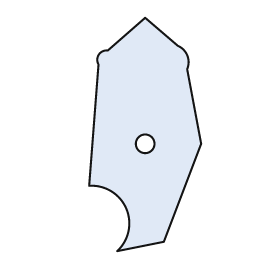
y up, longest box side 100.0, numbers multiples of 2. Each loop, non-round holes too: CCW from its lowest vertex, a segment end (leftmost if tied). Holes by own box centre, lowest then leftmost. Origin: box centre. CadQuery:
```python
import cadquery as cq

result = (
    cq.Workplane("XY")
    .moveTo(-12.0, -50.0)
    .lineTo(8.0, -46.0)
    .lineTo(24.0, -4.0)
    .lineTo(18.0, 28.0)
    .threePointArc((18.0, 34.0), (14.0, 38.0))
    .lineTo(0.0, 50.0)
    .lineTo(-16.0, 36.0)
    .threePointArc((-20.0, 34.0), (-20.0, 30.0))
    .lineTo(-24.0, -22.0)
    .threePointArc((-8.0, -32.0), (-12.0, -50.0))
    .close()
    .moveTo(0.0, -4.0)
    .circle(4.0)
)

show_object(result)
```